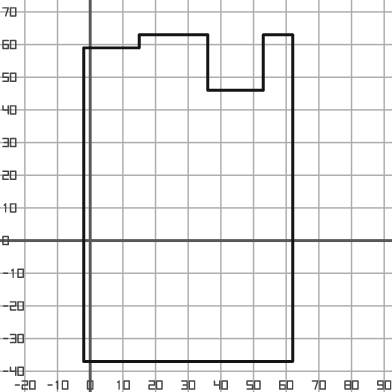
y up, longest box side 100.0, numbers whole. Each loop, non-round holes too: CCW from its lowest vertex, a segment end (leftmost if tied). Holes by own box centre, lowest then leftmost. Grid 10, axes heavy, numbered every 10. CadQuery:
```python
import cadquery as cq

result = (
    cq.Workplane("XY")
    .moveTo(-2.0, -37.0)
    .lineTo(62.0, -37.0)
    .lineTo(62.0, 63.0)
    .lineTo(53.0, 63.0)
    .lineTo(53.0, 46.0)
    .lineTo(36.0, 46.0)
    .lineTo(36.0, 63.0)
    .lineTo(15.0, 63.0)
    .lineTo(15.0, 59.0)
    .lineTo(-2.0, 59.0)
    .close()
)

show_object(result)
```